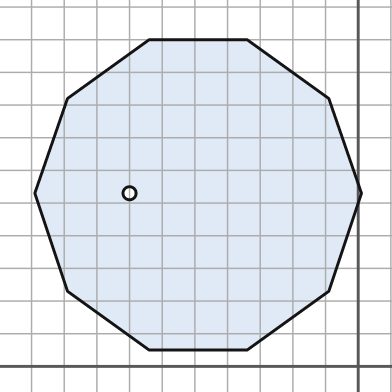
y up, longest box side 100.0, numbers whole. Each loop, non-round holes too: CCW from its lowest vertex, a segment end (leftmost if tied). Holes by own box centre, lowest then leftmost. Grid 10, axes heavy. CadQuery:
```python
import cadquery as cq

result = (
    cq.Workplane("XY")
    .moveTo(-64.0, 5.0)
    .lineTo(-34.0, 5.0)
    .lineTo(-9.0, 23.0)
    .lineTo(1.0, 53.0)
    .lineTo(-9.0, 82.0)
    .lineTo(-34.0, 100.0)
    .lineTo(-64.0, 100.0)
    .lineTo(-89.0, 82.0)
    .lineTo(-99.0, 53.0)
    .lineTo(-89.0, 23.0)
    .close()
    .moveTo(-70.0, 53.0)
    .circle(2.0)
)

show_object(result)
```